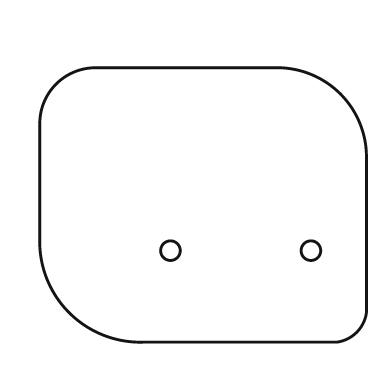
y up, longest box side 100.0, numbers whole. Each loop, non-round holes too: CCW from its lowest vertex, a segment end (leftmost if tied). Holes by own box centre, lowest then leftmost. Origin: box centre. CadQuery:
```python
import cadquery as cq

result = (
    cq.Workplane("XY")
    .moveTo(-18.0, -42.0)
    .lineTo(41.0, -42.0)
    .threePointArc((47.0, -39.0), (50.0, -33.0))
    .lineTo(50.0, 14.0)
    .threePointArc((42.0, 34.0), (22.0, 42.0))
    .lineTo(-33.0, 42.0)
    .threePointArc((-45.0, 37.0), (-50.0, 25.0))
    .lineTo(-50.0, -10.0)
    .threePointArc((-41.0, -33.0), (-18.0, -42.0))
    .close()
    .moveTo(-10.0, -14.0)
    .circle(3.0)
    .moveTo(33.0, -14.0)
    .circle(3.0)
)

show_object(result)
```